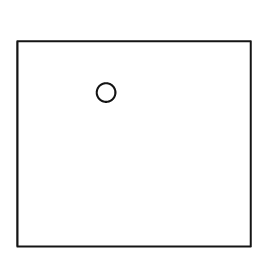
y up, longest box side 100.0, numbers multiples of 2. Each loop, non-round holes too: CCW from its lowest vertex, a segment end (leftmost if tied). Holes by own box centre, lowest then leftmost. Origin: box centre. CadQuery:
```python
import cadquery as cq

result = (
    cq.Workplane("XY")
    .moveTo(-50.0, -44.0)
    .lineTo(50.0, -44.0)
    .lineTo(50.0, 44.0)
    .lineTo(-50.0, 44.0)
    .close()
    .moveTo(-12.0, 22.0)
    .circle(4.0)
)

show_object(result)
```